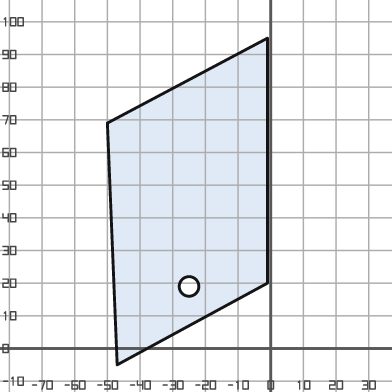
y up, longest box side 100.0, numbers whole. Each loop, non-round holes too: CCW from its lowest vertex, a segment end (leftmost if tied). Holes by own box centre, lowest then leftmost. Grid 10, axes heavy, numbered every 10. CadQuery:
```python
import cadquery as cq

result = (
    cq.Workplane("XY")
    .moveTo(-47.0, -5.0)
    .lineTo(-1.0, 20.0)
    .lineTo(-1.0, 95.0)
    .lineTo(-50.0, 69.0)
    .close()
    .moveTo(-25.0, 19.0)
    .circle(3.0)
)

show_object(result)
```